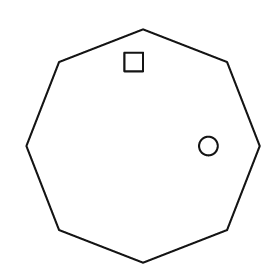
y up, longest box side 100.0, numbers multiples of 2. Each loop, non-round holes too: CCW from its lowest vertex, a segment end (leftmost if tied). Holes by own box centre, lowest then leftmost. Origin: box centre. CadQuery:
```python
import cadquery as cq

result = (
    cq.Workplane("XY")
    .moveTo(0.0, -50.0)
    .lineTo(36.0, -36.0)
    .lineTo(50.0, 0.0)
    .lineTo(36.0, 36.0)
    .lineTo(0.0, 50.0)
    .lineTo(-36.0, 36.0)
    .lineTo(-50.0, 0.0)
    .lineTo(-36.0, -36.0)
    .close()
    .moveTo(28.0, 0.0)
    .circle(4.0)
    .moveTo(-8.0, 32.0)
    .lineTo(0.0, 32.0)
    .lineTo(0.0, 40.0)
    .lineTo(-8.0, 40.0)
    .close()
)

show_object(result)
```